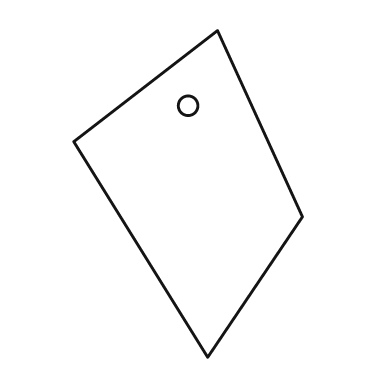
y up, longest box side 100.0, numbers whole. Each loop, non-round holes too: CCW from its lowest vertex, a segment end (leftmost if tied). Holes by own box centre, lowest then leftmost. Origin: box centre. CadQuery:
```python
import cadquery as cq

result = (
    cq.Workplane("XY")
    .moveTo(6.0, -50.0)
    .lineTo(35.0, -7.0)
    .lineTo(9.0, 50.0)
    .lineTo(-35.0, 16.0)
    .close()
    .moveTo(0.0, 27.0)
    .circle(3.0)
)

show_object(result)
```